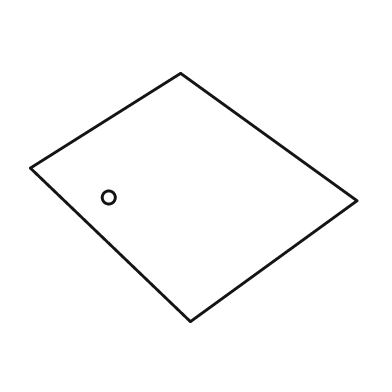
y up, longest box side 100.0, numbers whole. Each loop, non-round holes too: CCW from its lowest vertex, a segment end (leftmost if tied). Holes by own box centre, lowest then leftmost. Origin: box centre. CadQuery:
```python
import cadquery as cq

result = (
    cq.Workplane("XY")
    .moveTo(-1.0, -38.0)
    .lineTo(50.0, -1.0)
    .lineTo(-4.0, 38.0)
    .lineTo(-50.0, 9.0)
    .close()
    .moveTo(-26.0, 0.0)
    .circle(2.0)
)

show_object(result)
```